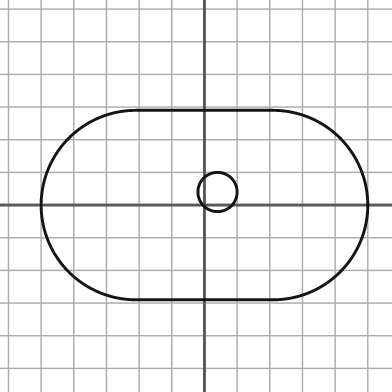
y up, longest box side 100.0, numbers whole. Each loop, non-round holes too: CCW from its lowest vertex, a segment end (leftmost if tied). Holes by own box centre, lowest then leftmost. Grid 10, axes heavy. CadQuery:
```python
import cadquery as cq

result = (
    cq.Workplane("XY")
    .moveTo(-21.0, -29.0)
    .lineTo(21.0, -29.0)
    .threePointArc((50.0, 0.0), (21.0, 29.0))
    .lineTo(-21.0, 29.0)
    .threePointArc((-50.0, 0.0), (-21.0, -29.0))
    .close()
    .moveTo(4.0, 4.0)
    .circle(6.0)
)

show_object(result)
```